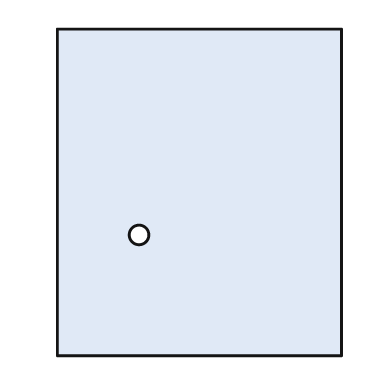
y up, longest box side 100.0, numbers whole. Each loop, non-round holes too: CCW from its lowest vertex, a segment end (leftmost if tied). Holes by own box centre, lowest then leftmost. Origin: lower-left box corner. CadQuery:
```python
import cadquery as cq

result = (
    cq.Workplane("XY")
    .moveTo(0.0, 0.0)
    .lineTo(87.0, 0.0)
    .lineTo(87.0, 100.0)
    .lineTo(0.0, 100.0)
    .close()
    .moveTo(25.0, 37.0)
    .circle(3.0)
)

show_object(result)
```